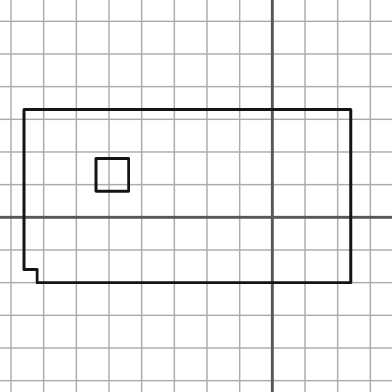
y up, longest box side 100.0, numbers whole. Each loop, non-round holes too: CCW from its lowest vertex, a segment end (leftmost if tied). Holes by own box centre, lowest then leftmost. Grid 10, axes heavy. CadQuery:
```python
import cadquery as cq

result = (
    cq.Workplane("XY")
    .moveTo(-72.0, -20.0)
    .lineTo(24.0, -20.0)
    .lineTo(24.0, 33.0)
    .lineTo(-76.0, 33.0)
    .lineTo(-76.0, -16.0)
    .lineTo(-72.0, -16.0)
    .close()
    .moveTo(-54.0, 8.0)
    .lineTo(-44.0, 8.0)
    .lineTo(-44.0, 18.0)
    .lineTo(-54.0, 18.0)
    .close()
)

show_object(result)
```